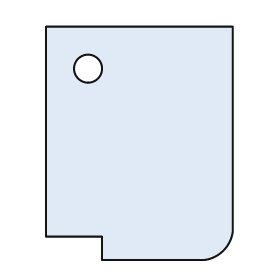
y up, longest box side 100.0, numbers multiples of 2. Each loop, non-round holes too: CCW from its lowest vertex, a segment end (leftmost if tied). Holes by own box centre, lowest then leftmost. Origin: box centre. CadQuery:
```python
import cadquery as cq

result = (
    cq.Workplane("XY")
    .moveTo(-16.0, -50.0)
    .lineTo(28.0, -50.0)
    .threePointArc((36.0, -46.0), (40.0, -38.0))
    .lineTo(40.0, 50.0)
    .lineTo(-40.0, 50.0)
    .lineTo(-40.0, -40.0)
    .lineTo(-16.0, -40.0)
    .close()
    .moveTo(-22.0, 32.0)
    .circle(6.0)
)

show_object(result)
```